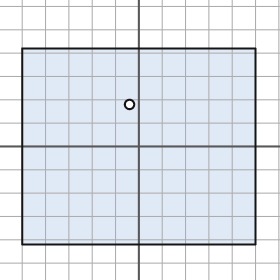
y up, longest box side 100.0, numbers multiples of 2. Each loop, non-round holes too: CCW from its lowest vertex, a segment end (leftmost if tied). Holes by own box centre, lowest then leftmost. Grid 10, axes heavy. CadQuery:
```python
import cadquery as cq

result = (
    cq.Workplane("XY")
    .moveTo(-50.0, -42.0)
    .lineTo(50.0, -42.0)
    .lineTo(50.0, 42.0)
    .lineTo(-50.0, 42.0)
    .close()
    .moveTo(-4.0, 18.0)
    .circle(2.0)
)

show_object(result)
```